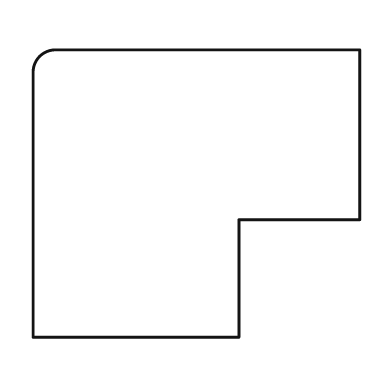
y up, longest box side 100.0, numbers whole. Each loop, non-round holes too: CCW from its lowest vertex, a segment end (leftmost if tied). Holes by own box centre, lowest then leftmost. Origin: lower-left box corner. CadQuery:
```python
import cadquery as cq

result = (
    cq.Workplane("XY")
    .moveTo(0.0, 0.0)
    .lineTo(63.0, 0.0)
    .lineTo(63.0, 36.0)
    .lineTo(100.0, 36.0)
    .lineTo(100.0, 88.0)
    .lineTo(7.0, 88.0)
    .threePointArc((2.0, 86.0), (0.0, 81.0))
    .close()
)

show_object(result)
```